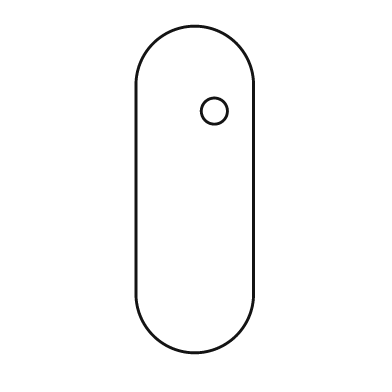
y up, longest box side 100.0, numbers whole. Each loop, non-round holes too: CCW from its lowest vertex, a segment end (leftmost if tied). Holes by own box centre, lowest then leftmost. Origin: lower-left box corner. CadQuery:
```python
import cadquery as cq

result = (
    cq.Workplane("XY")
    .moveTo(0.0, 18.0)
    .threePointArc((18.0, 0.0), (36.0, 18.0))
    .lineTo(36.0, 82.0)
    .threePointArc((18.0, 100.0), (0.0, 82.0))
    .close()
    .moveTo(24.0, 74.0)
    .circle(4.0)
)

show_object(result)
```